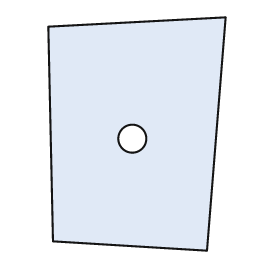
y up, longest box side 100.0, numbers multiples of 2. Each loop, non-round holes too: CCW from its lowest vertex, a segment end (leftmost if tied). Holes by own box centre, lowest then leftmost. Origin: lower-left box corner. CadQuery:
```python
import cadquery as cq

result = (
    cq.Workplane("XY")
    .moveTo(68.0, 0.0)
    .lineTo(76.0, 100.0)
    .lineTo(0.0, 96.0)
    .lineTo(2.0, 4.0)
    .close()
    .moveTo(36.0, 48.0)
    .circle(6.0)
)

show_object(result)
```